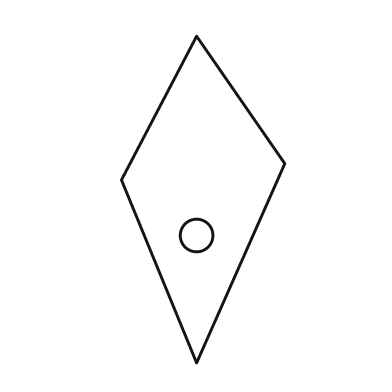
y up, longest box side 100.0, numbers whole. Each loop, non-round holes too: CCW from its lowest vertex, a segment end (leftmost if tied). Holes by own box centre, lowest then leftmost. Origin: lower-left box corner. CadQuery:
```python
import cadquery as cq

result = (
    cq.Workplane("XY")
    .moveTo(23.0, 0.0)
    .lineTo(50.0, 61.0)
    .lineTo(23.0, 100.0)
    .lineTo(0.0, 56.0)
    .close()
    .moveTo(23.0, 39.0)
    .circle(5.0)
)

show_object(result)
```